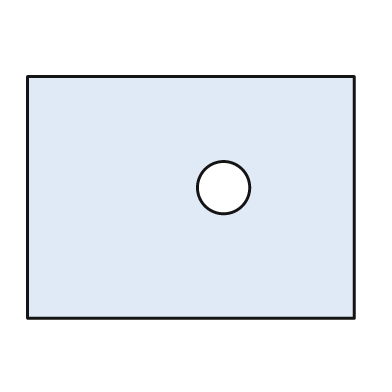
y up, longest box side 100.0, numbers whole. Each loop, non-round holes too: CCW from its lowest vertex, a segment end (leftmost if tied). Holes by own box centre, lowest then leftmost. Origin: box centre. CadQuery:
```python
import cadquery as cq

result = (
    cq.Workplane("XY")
    .moveTo(-50.0, -37.0)
    .lineTo(50.0, -37.0)
    .lineTo(50.0, 37.0)
    .lineTo(-50.0, 37.0)
    .close()
    .moveTo(10.0, 3.0)
    .circle(8.0)
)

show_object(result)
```